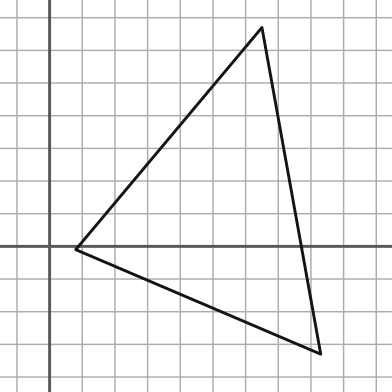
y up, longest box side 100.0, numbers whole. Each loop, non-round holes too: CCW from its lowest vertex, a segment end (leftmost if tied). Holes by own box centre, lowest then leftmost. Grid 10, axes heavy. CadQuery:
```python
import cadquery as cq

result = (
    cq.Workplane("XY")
    .moveTo(83.0, -33.0)
    .lineTo(65.0, 67.0)
    .lineTo(8.0, -1.0)
    .close()
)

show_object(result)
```